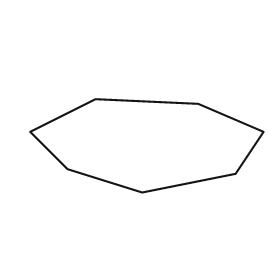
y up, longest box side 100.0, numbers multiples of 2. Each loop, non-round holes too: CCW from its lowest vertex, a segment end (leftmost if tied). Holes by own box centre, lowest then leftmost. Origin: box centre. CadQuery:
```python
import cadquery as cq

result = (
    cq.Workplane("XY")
    .moveTo(-2.0, -20.0)
    .lineTo(38.0, -12.0)
    .lineTo(50.0, 6.0)
    .lineTo(22.0, 18.0)
    .lineTo(-22.0, 20.0)
    .lineTo(-50.0, 6.0)
    .lineTo(-34.0, -10.0)
    .close()
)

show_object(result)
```